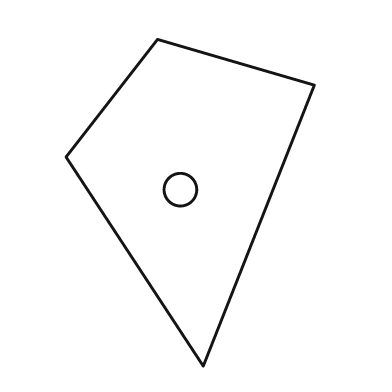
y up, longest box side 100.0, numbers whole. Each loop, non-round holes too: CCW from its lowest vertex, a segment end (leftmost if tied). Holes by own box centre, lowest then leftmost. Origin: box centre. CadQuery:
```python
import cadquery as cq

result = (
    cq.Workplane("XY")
    .moveTo(4.0, -50.0)
    .lineTo(38.0, 36.0)
    .lineTo(-10.0, 50.0)
    .lineTo(-38.0, 14.0)
    .close()
    .moveTo(-3.0, 4.0)
    .circle(5.0)
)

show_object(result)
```